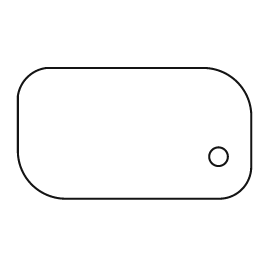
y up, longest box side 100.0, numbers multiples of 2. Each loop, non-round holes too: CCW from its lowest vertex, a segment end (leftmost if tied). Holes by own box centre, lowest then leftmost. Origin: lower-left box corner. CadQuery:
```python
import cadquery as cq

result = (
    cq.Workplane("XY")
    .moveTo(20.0, 0.0)
    .lineTo(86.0, 0.0)
    .threePointArc((96.0, 4.0), (100.0, 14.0))
    .lineTo(100.0, 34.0)
    .threePointArc((94.0, 50.0), (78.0, 56.0))
    .lineTo(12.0, 56.0)
    .threePointArc((4.0, 52.0), (0.0, 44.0))
    .lineTo(0.0, 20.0)
    .threePointArc((6.0, 6.0), (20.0, 0.0))
    .close()
    .moveTo(86.0, 18.0)
    .circle(4.0)
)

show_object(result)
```